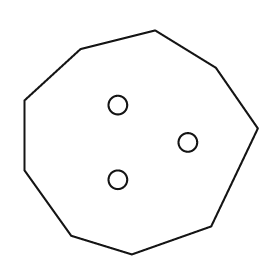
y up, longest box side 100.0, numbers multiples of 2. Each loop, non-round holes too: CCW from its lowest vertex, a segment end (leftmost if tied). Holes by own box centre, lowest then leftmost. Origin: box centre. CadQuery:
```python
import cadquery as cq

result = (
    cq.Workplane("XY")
    .moveTo(-4.0, -48.0)
    .lineTo(30.0, -36.0)
    .lineTo(50.0, 6.0)
    .lineTo(32.0, 32.0)
    .lineTo(6.0, 48.0)
    .lineTo(-26.0, 40.0)
    .lineTo(-50.0, 18.0)
    .lineTo(-50.0, -12.0)
    .lineTo(-30.0, -40.0)
    .close()
    .moveTo(-10.0, -16.0)
    .circle(4.0)
    .moveTo(20.0, 0.0)
    .circle(4.0)
    .moveTo(-10.0, 16.0)
    .circle(4.0)
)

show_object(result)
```